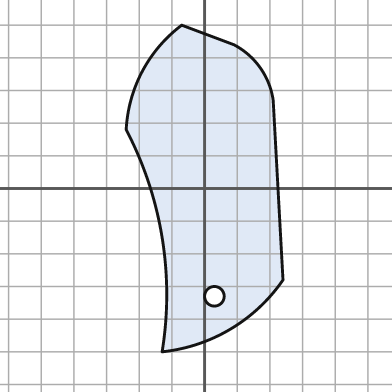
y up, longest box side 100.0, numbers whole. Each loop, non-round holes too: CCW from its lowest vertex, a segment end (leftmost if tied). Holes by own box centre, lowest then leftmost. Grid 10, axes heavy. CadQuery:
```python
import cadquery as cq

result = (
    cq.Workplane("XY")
    .moveTo(-13.0, -50.0)
    .threePointArc((8.0, -43.0), (24.0, -28.0))
    .lineTo(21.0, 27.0)
    .threePointArc((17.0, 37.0), (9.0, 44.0))
    .lineTo(-7.0, 50.0)
    .threePointArc((-19.0, 36.0), (-24.0, 18.0))
    .threePointArc((-13.0, -15.0), (-13.0, -50.0))
    .close()
    .moveTo(3.0, -33.0)
    .circle(3.0)
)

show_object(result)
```